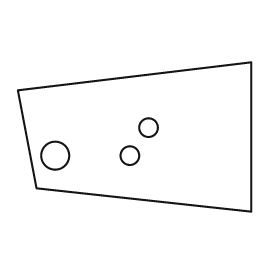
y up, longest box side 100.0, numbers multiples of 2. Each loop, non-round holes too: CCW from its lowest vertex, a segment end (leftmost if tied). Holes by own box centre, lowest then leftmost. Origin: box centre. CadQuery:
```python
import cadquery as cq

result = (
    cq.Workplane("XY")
    .moveTo(50.0, -32.0)
    .lineTo(50.0, 32.0)
    .lineTo(-50.0, 20.0)
    .lineTo(-42.0, -22.0)
    .close()
    .moveTo(-34.0, -8.0)
    .circle(6.0)
    .moveTo(-2.0, -8.0)
    .circle(4.0)
    .moveTo(6.0, 4.0)
    .circle(4.0)
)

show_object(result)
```